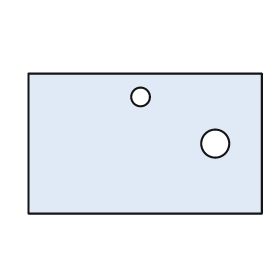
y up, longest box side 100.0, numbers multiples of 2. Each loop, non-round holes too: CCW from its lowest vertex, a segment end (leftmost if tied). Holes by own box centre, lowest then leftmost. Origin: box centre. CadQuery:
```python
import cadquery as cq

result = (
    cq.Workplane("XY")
    .moveTo(-50.0, -30.0)
    .lineTo(50.0, -30.0)
    .lineTo(50.0, 30.0)
    .lineTo(-50.0, 30.0)
    .close()
    .moveTo(30.0, 0.0)
    .circle(6.0)
    .moveTo(-2.0, 20.0)
    .circle(4.0)
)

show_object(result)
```